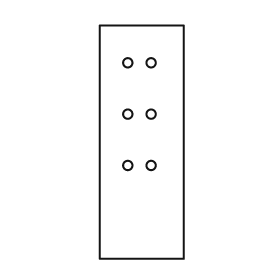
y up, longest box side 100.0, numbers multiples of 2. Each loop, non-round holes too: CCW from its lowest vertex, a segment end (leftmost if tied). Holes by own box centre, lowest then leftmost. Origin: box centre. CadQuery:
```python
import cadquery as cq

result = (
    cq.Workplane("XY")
    .moveTo(-18.0, -50.0)
    .lineTo(18.0, -50.0)
    .lineTo(18.0, 50.0)
    .lineTo(-18.0, 50.0)
    .close()
    .moveTo(-6.0, -10.0)
    .circle(2.0)
    .moveTo(4.0, -10.0)
    .circle(2.0)
    .moveTo(-6.0, 12.0)
    .circle(2.0)
    .moveTo(4.0, 12.0)
    .circle(2.0)
    .moveTo(-6.0, 34.0)
    .circle(2.0)
    .moveTo(4.0, 34.0)
    .circle(2.0)
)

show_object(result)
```